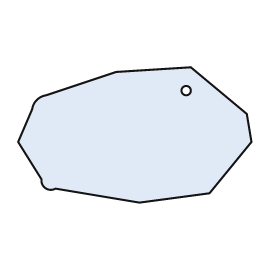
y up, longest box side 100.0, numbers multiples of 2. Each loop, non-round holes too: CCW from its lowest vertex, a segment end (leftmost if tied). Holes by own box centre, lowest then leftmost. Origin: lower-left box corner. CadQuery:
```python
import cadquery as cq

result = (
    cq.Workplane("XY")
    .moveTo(52.0, 0.0)
    .lineTo(82.0, 4.0)
    .lineTo(100.0, 26.0)
    .lineTo(98.0, 38.0)
    .lineTo(74.0, 58.0)
    .lineTo(42.0, 56.0)
    .lineTo(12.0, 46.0)
    .threePointArc((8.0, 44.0), (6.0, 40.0))
    .lineTo(0.0, 26.0)
    .lineTo(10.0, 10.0)
    .threePointArc((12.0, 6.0), (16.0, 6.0))
    .close()
    .moveTo(72.0, 48.0)
    .circle(2.0)
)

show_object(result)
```